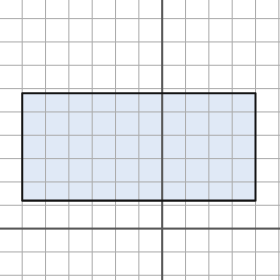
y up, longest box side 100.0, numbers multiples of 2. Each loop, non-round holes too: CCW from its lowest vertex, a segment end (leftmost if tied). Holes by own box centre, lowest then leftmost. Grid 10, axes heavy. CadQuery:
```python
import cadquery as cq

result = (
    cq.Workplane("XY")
    .moveTo(-60.0, 12.0)
    .lineTo(40.0, 12.0)
    .lineTo(40.0, 58.0)
    .lineTo(-60.0, 58.0)
    .close()
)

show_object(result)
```